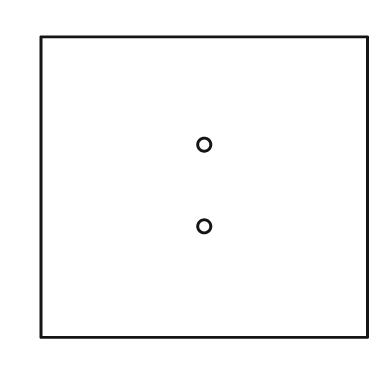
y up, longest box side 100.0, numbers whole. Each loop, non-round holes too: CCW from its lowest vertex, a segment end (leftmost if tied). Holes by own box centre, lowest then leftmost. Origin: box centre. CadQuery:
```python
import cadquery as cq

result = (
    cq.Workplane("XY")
    .moveTo(-50.0, -46.0)
    .lineTo(50.0, -46.0)
    .lineTo(50.0, 46.0)
    .lineTo(-50.0, 46.0)
    .close()
    .moveTo(0.0, -12.0)
    .circle(2.0)
    .moveTo(0.0, 13.0)
    .circle(2.0)
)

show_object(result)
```